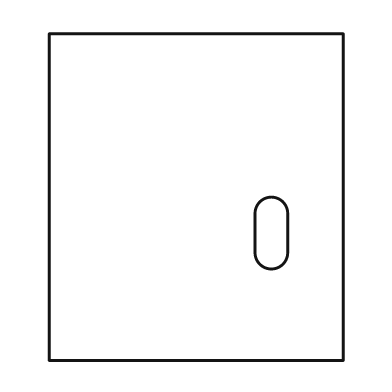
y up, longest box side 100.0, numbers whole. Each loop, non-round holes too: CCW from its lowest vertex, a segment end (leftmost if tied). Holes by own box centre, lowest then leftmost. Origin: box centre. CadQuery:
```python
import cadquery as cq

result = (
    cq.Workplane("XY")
    .moveTo(-45.0, -50.0)
    .lineTo(45.0, -50.0)
    .lineTo(45.0, 50.0)
    .lineTo(-45.0, 50.0)
    .close()
    .moveTo(18.0, -17.0)
    .threePointArc((23.0, -22.0), (28.0, -17.0))
    .lineTo(28.0, -5.0)
    .threePointArc((23.0, 0.0), (18.0, -5.0))
    .close()
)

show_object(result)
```